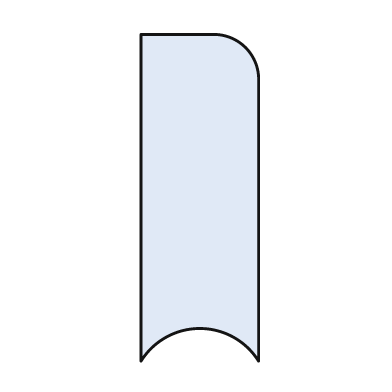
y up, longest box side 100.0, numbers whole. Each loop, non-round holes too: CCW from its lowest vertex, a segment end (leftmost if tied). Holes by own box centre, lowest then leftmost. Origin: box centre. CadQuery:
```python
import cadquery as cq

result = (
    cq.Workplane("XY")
    .moveTo(-18.0, -50.0)
    .threePointArc((0.0, -40.0), (18.0, -50.0))
    .lineTo(18.0, 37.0)
    .threePointArc((14.0, 46.0), (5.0, 50.0))
    .lineTo(-18.0, 50.0)
    .close()
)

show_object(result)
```